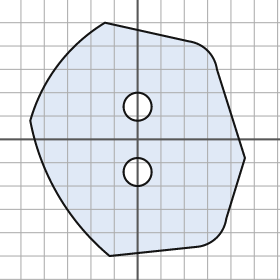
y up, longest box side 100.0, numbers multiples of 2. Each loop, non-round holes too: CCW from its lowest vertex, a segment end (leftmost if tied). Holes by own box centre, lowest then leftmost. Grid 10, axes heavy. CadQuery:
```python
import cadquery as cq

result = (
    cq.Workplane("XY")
    .moveTo(-12.0, -50.0)
    .lineTo(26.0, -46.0)
    .threePointArc((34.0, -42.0), (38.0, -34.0))
    .lineTo(46.0, -8.0)
    .lineTo(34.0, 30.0)
    .threePointArc((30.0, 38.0), (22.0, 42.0))
    .lineTo(-14.0, 50.0)
    .threePointArc((-34.0, 32.0), (-46.0, 8.0))
    .threePointArc((-34.0, -24.0), (-12.0, -50.0))
    .close()
    .moveTo(0.0, -14.0)
    .circle(6.0)
    .moveTo(0.0, 14.0)
    .circle(6.0)
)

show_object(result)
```